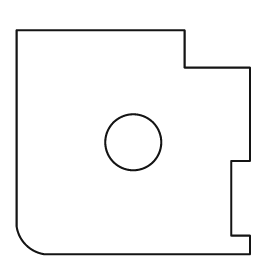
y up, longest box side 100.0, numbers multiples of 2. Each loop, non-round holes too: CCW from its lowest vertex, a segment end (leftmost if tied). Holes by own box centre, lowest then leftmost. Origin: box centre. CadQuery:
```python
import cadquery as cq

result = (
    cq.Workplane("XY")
    .moveTo(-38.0, -48.0)
    .lineTo(50.0, -48.0)
    .lineTo(50.0, -40.0)
    .lineTo(42.0, -40.0)
    .lineTo(42.0, -8.0)
    .lineTo(50.0, -8.0)
    .lineTo(50.0, 32.0)
    .lineTo(22.0, 32.0)
    .lineTo(22.0, 48.0)
    .lineTo(-50.0, 48.0)
    .lineTo(-50.0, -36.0)
    .threePointArc((-46.0, -44.0), (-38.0, -48.0))
    .close()
    .moveTo(0.0, 0.0)
    .circle(12.0)
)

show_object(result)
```